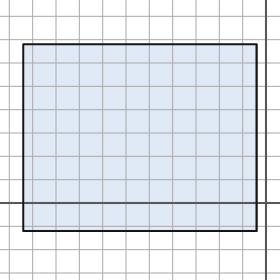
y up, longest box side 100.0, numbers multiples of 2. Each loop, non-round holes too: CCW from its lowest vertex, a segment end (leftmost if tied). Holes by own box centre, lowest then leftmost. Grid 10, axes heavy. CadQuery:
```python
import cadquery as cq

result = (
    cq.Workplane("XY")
    .moveTo(-104.0, -12.0)
    .lineTo(-4.0, -12.0)
    .lineTo(-4.0, 68.0)
    .lineTo(-104.0, 68.0)
    .close()
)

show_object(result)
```